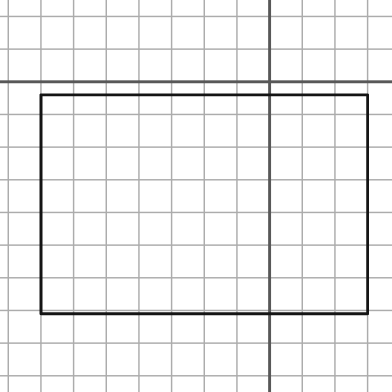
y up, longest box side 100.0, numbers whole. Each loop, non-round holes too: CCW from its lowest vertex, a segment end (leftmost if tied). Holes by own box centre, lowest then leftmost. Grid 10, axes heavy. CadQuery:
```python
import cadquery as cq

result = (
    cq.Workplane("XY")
    .moveTo(-70.0, -71.0)
    .lineTo(30.0, -71.0)
    .lineTo(30.0, -4.0)
    .lineTo(-70.0, -4.0)
    .close()
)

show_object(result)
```